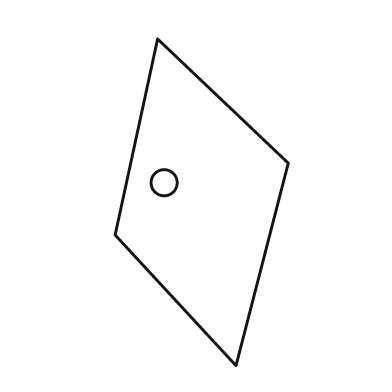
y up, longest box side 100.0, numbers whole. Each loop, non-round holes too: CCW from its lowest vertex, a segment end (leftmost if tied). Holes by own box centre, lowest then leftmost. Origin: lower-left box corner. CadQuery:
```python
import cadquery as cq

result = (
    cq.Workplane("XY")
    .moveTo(37.0, 0.0)
    .lineTo(53.0, 62.0)
    .lineTo(13.0, 100.0)
    .lineTo(0.0, 40.0)
    .close()
    .moveTo(15.0, 56.0)
    .circle(4.0)
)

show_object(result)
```